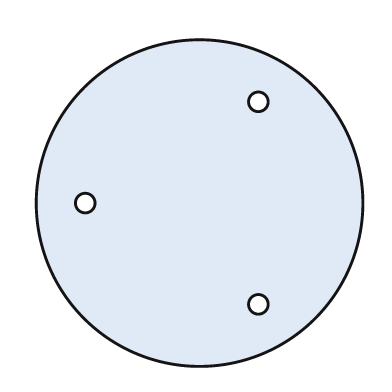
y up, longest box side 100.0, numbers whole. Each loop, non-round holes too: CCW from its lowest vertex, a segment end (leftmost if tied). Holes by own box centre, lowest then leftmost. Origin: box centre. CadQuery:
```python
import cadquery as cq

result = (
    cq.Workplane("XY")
    .moveTo(0.0, 0.0)
    .circle(50.0)
    .moveTo(18.0, -31.0)
    .circle(3.0)
    .moveTo(-35.0, 0.0)
    .circle(3.0)
    .moveTo(18.0, 31.0)
    .circle(3.0)
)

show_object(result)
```